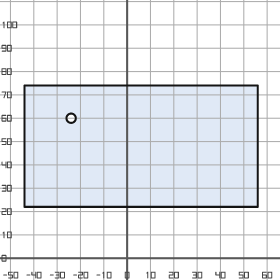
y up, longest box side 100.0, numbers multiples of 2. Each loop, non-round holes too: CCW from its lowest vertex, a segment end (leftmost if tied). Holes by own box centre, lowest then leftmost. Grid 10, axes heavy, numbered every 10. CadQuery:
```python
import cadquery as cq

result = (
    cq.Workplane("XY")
    .moveTo(-44.0, 22.0)
    .lineTo(56.0, 22.0)
    .lineTo(56.0, 74.0)
    .lineTo(-44.0, 74.0)
    .close()
    .moveTo(-24.0, 60.0)
    .circle(2.0)
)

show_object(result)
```